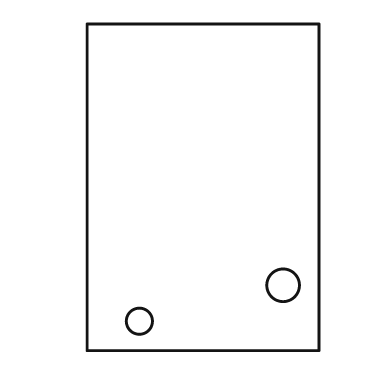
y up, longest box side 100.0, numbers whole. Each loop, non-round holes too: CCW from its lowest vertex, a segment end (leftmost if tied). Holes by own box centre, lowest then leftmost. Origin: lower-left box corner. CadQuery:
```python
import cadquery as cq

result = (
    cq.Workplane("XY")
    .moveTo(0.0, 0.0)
    .lineTo(71.0, 0.0)
    .lineTo(71.0, 100.0)
    .lineTo(0.0, 100.0)
    .close()
    .moveTo(16.0, 9.0)
    .circle(4.0)
    .moveTo(60.0, 20.0)
    .circle(5.0)
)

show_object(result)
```